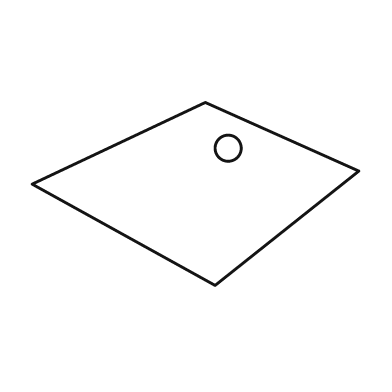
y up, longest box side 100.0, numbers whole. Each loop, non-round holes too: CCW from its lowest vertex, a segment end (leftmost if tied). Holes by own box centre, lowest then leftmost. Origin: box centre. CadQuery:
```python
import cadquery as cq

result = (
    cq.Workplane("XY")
    .moveTo(6.0, -28.0)
    .lineTo(50.0, 7.0)
    .lineTo(3.0, 28.0)
    .lineTo(-50.0, 3.0)
    .close()
    .moveTo(10.0, 14.0)
    .circle(4.0)
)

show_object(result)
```